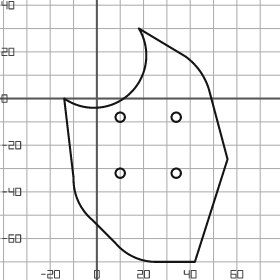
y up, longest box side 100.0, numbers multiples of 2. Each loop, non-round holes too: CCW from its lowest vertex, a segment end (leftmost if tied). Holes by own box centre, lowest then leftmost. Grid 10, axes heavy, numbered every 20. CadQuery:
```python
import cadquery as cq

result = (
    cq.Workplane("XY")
    .moveTo(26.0, -70.0)
    .lineTo(42.0, -70.0)
    .lineTo(56.0, -26.0)
    .lineTo(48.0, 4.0)
    .threePointArc((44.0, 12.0), (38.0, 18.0))
    .lineTo(18.0, 30.0)
    .threePointArc((14.0, 2.0), (-14.0, 0.0))
    .lineTo(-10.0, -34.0)
    .threePointArc((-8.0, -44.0), (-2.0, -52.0))
    .lineTo(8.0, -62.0)
    .threePointArc((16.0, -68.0), (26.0, -70.0))
    .close()
    .moveTo(10.0, -32.0)
    .circle(2.0)
    .moveTo(34.0, -32.0)
    .circle(2.0)
    .moveTo(10.0, -8.0)
    .circle(2.0)
    .moveTo(34.0, -8.0)
    .circle(2.0)
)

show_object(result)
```